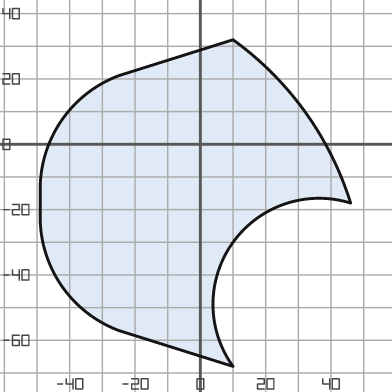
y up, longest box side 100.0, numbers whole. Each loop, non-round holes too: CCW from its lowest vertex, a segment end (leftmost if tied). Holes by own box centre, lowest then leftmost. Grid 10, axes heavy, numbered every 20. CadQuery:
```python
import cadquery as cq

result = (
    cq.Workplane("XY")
    .moveTo(10.0, -68.0)
    .threePointArc((10.0, -30.0), (46.0, -18.0))
    .threePointArc((32.0, 10.0), (10.0, 32.0))
    .lineTo(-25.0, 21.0)
    .threePointArc((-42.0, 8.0), (-49.0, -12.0))
    .lineTo(-49.0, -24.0)
    .threePointArc((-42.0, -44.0), (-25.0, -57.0))
    .close()
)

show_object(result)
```